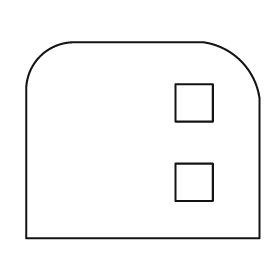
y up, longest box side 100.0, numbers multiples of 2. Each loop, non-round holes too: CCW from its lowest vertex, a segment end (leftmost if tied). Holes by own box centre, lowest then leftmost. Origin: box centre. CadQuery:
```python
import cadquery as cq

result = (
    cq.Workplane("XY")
    .moveTo(-50.0, -42.0)
    .lineTo(50.0, -42.0)
    .lineTo(50.0, 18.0)
    .threePointArc((42.0, 34.0), (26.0, 42.0))
    .lineTo(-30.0, 42.0)
    .threePointArc((-44.0, 36.0), (-50.0, 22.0))
    .close()
    .moveTo(14.0, -26.0)
    .lineTo(30.0, -26.0)
    .lineTo(30.0, -10.0)
    .lineTo(14.0, -10.0)
    .close()
    .moveTo(14.0, 8.0)
    .lineTo(30.0, 8.0)
    .lineTo(30.0, 24.0)
    .lineTo(14.0, 24.0)
    .close()
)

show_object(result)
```